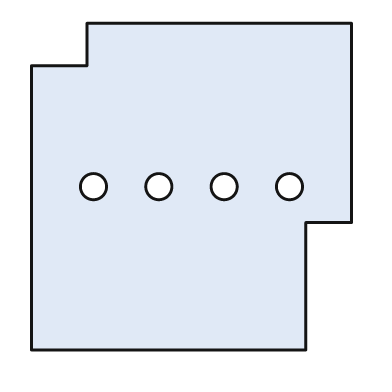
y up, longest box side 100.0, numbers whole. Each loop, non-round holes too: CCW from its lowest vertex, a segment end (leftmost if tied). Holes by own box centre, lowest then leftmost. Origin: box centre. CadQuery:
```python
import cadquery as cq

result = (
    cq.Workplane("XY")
    .moveTo(-49.0, -50.0)
    .lineTo(35.0, -50.0)
    .lineTo(35.0, -11.0)
    .lineTo(49.0, -11.0)
    .lineTo(49.0, 50.0)
    .lineTo(-32.0, 50.0)
    .lineTo(-32.0, 37.0)
    .lineTo(-49.0, 37.0)
    .close()
    .moveTo(-30.0, 0.0)
    .circle(4.0)
    .moveTo(-10.0, 0.0)
    .circle(4.0)
    .moveTo(10.0, 0.0)
    .circle(4.0)
    .moveTo(30.0, 0.0)
    .circle(4.0)
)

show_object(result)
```